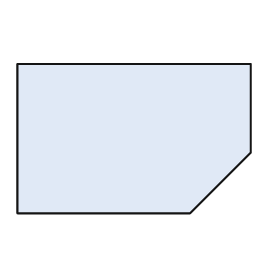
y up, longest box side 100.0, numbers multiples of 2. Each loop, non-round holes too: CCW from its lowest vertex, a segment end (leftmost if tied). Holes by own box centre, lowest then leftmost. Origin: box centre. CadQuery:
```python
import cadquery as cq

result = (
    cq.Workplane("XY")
    .moveTo(-50.0, -32.0)
    .lineTo(24.0, -32.0)
    .lineTo(50.0, -6.0)
    .lineTo(50.0, 32.0)
    .lineTo(-50.0, 32.0)
    .close()
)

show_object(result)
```